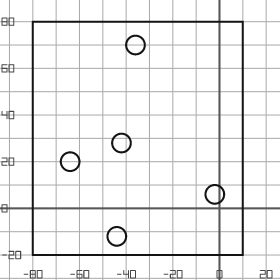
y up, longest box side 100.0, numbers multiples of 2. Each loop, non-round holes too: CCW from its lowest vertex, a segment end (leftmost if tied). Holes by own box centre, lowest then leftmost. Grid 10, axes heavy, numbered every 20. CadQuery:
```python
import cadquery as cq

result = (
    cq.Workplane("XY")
    .moveTo(-80.0, -20.0)
    .lineTo(10.0, -20.0)
    .lineTo(10.0, 80.0)
    .lineTo(-80.0, 80.0)
    .close()
    .moveTo(-44.0, -12.0)
    .circle(4.0)
    .moveTo(-2.0, 6.0)
    .circle(4.0)
    .moveTo(-64.0, 20.0)
    .circle(4.0)
    .moveTo(-42.0, 28.0)
    .circle(4.0)
    .moveTo(-36.0, 70.0)
    .circle(4.0)
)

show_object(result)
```